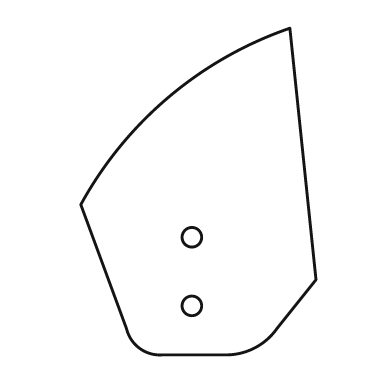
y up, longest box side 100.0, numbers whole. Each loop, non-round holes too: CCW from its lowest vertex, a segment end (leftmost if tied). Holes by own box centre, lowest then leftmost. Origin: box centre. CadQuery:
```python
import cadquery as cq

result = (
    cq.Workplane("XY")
    .moveTo(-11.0, -50.0)
    .lineTo(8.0, -50.0)
    .threePointArc((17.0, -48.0), (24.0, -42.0))
    .lineTo(36.0, -27.0)
    .lineTo(28.0, 50.0)
    .threePointArc((-9.0, 29.0), (-36.0, -4.0))
    .lineTo(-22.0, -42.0)
    .threePointArc((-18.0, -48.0), (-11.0, -50.0))
    .close()
    .moveTo(-2.0, -35.0)
    .circle(3.0)
    .moveTo(-2.0, -14.0)
    .circle(3.0)
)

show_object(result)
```